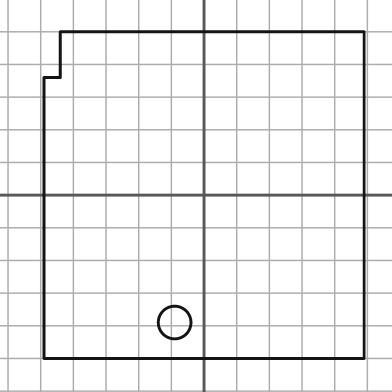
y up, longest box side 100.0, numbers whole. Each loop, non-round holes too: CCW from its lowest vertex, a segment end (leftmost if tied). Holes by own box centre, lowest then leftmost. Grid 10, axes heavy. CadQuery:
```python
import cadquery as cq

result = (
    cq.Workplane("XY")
    .moveTo(-49.0, -50.0)
    .lineTo(49.0, -50.0)
    .lineTo(49.0, 50.0)
    .lineTo(-44.0, 50.0)
    .lineTo(-44.0, 36.0)
    .lineTo(-49.0, 36.0)
    .close()
    .moveTo(-9.0, -39.0)
    .circle(5.0)
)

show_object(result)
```